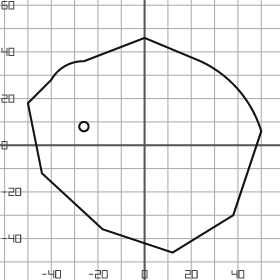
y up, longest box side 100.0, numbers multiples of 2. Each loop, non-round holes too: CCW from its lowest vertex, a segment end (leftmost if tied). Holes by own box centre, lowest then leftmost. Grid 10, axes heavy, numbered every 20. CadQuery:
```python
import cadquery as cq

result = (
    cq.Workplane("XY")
    .moveTo(12.0, -46.0)
    .lineTo(38.0, -30.0)
    .lineTo(50.0, 6.0)
    .threePointArc((40.0, 24.0), (24.0, 36.0))
    .lineTo(0.0, 46.0)
    .lineTo(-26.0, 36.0)
    .threePointArc((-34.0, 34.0), (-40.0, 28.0))
    .lineTo(-50.0, 18.0)
    .lineTo(-44.0, -12.0)
    .lineTo(-18.0, -36.0)
    .close()
    .moveTo(-26.0, 8.0)
    .circle(2.0)
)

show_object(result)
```